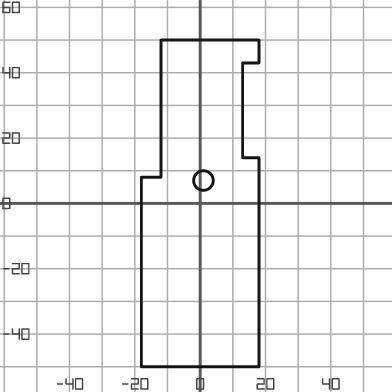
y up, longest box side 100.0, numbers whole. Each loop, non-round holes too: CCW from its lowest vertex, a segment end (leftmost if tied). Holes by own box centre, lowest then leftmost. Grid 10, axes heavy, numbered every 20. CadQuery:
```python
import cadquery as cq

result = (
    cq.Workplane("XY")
    .moveTo(-18.0, -50.0)
    .lineTo(18.0, -50.0)
    .lineTo(18.0, 14.0)
    .lineTo(13.0, 14.0)
    .lineTo(13.0, 43.0)
    .lineTo(18.0, 43.0)
    .lineTo(18.0, 50.0)
    .lineTo(-12.0, 50.0)
    .lineTo(-12.0, 8.0)
    .lineTo(-18.0, 8.0)
    .close()
    .moveTo(1.0, 7.0)
    .circle(3.0)
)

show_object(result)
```